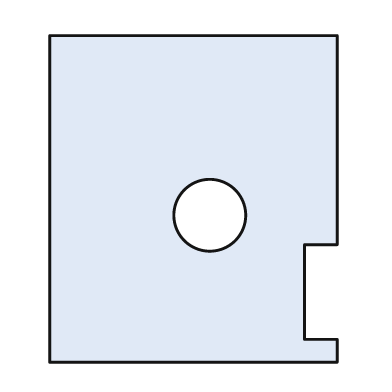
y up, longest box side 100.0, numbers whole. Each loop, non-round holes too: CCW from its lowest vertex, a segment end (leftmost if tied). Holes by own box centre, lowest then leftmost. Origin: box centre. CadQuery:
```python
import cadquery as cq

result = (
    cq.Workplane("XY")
    .moveTo(-44.0, -50.0)
    .lineTo(44.0, -50.0)
    .lineTo(44.0, -43.0)
    .lineTo(34.0, -43.0)
    .lineTo(34.0, -14.0)
    .lineTo(44.0, -14.0)
    .lineTo(44.0, 50.0)
    .lineTo(-44.0, 50.0)
    .close()
    .moveTo(5.0, -5.0)
    .circle(11.0)
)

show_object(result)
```